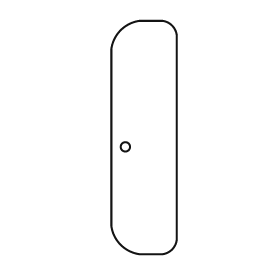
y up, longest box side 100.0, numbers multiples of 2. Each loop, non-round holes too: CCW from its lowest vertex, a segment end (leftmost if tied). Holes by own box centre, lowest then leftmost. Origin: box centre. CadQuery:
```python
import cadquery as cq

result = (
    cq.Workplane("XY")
    .moveTo(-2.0, -50.0)
    .lineTo(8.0, -50.0)
    .threePointArc((12.0, -48.0), (14.0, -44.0))
    .lineTo(14.0, 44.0)
    .threePointArc((12.0, 48.0), (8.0, 50.0))
    .lineTo(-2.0, 50.0)
    .threePointArc((-10.0, 46.0), (-14.0, 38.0))
    .lineTo(-14.0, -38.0)
    .threePointArc((-10.0, -46.0), (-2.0, -50.0))
    .close()
    .moveTo(-8.0, -4.0)
    .circle(2.0)
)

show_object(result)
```